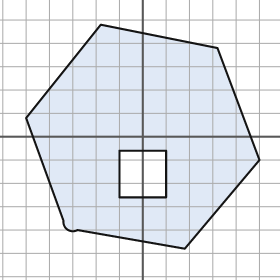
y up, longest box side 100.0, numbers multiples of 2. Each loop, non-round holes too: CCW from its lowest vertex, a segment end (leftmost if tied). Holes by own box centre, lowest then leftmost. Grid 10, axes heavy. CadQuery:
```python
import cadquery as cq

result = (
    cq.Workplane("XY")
    .moveTo(18.0, -48.0)
    .lineTo(50.0, -10.0)
    .lineTo(32.0, 38.0)
    .lineTo(-18.0, 48.0)
    .lineTo(-50.0, 8.0)
    .lineTo(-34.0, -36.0)
    .threePointArc((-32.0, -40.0), (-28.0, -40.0))
    .close()
    .moveTo(-10.0, -26.0)
    .lineTo(10.0, -26.0)
    .lineTo(10.0, -6.0)
    .lineTo(-10.0, -6.0)
    .close()
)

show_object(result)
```